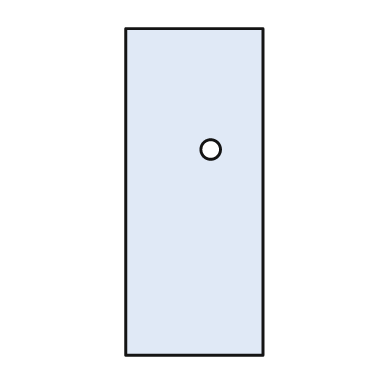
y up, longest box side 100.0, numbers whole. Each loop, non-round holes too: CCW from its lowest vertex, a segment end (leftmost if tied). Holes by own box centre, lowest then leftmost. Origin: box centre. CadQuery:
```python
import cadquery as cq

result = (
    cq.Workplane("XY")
    .moveTo(-21.0, -50.0)
    .lineTo(21.0, -50.0)
    .lineTo(21.0, 50.0)
    .lineTo(-21.0, 50.0)
    .close()
    .moveTo(5.0, 13.0)
    .circle(3.0)
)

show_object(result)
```